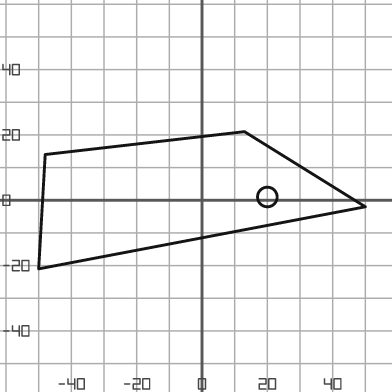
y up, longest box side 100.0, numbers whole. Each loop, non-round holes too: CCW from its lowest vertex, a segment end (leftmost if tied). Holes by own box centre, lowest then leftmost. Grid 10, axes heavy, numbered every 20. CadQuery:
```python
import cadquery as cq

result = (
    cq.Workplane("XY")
    .moveTo(-50.0, -21.0)
    .lineTo(50.0, -2.0)
    .lineTo(13.0, 21.0)
    .lineTo(-48.0, 14.0)
    .close()
    .moveTo(20.0, 1.0)
    .circle(3.0)
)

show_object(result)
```